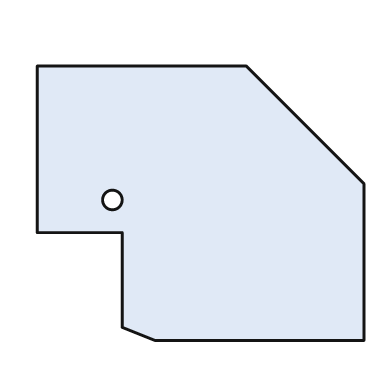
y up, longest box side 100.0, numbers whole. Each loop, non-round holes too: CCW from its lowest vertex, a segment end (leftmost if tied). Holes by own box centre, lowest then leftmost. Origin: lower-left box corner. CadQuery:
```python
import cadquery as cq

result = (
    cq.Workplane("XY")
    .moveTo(36.0, 0.0)
    .lineTo(100.0, 0.0)
    .lineTo(100.0, 48.0)
    .lineTo(64.0, 84.0)
    .lineTo(0.0, 84.0)
    .lineTo(0.0, 33.0)
    .lineTo(26.0, 33.0)
    .lineTo(26.0, 4.0)
    .close()
    .moveTo(23.0, 43.0)
    .circle(3.0)
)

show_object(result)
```